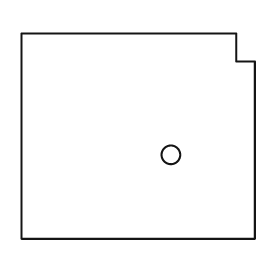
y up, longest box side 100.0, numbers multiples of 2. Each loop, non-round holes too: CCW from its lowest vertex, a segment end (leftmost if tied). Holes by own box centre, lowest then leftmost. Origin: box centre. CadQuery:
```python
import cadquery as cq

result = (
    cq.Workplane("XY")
    .moveTo(-50.0, -44.0)
    .lineTo(50.0, -44.0)
    .lineTo(50.0, 32.0)
    .lineTo(42.0, 32.0)
    .lineTo(42.0, 44.0)
    .lineTo(-50.0, 44.0)
    .close()
    .moveTo(14.0, -8.0)
    .circle(4.0)
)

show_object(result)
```